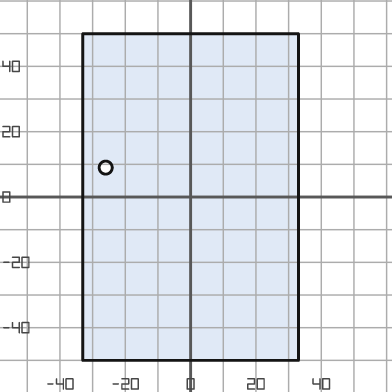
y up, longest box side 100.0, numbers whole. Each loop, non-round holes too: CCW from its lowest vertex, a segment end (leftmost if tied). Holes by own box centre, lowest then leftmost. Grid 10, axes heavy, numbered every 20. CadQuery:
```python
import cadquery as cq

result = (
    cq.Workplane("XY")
    .moveTo(-33.0, -50.0)
    .lineTo(33.0, -50.0)
    .lineTo(33.0, 50.0)
    .lineTo(-33.0, 50.0)
    .close()
    .moveTo(-26.0, 9.0)
    .circle(2.0)
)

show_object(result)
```